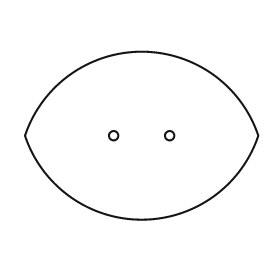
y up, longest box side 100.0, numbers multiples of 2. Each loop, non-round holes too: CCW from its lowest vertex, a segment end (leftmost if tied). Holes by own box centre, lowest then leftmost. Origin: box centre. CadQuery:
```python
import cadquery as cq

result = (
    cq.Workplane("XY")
    .moveTo(-50.0, 0.0)
    .threePointArc((0.0, -36.0), (50.0, 0.0))
    .threePointArc((0.0, 36.0), (-50.0, 0.0))
    .close()
    .moveTo(-12.0, 0.0)
    .circle(2.0)
    .moveTo(12.0, 0.0)
    .circle(2.0)
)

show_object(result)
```